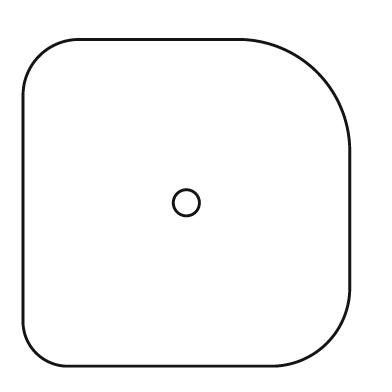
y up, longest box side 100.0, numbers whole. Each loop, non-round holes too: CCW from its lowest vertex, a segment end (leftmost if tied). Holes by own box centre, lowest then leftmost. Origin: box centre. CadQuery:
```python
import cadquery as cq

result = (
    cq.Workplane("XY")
    .moveTo(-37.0, -50.0)
    .lineTo(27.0, -50.0)
    .threePointArc((43.0, -43.0), (50.0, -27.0))
    .lineTo(50.0, 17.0)
    .threePointArc((40.0, 40.0), (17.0, 50.0))
    .lineTo(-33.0, 50.0)
    .threePointArc((-45.0, 45.0), (-50.0, 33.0))
    .lineTo(-50.0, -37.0)
    .threePointArc((-46.0, -46.0), (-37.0, -50.0))
    .close()
    .moveTo(0.0, 0.0)
    .circle(4.0)
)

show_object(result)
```